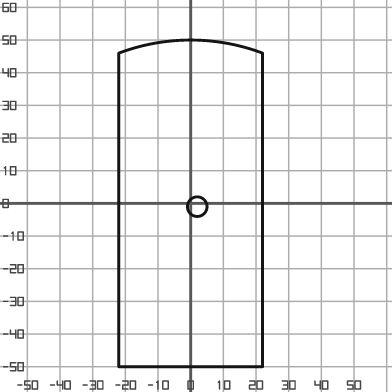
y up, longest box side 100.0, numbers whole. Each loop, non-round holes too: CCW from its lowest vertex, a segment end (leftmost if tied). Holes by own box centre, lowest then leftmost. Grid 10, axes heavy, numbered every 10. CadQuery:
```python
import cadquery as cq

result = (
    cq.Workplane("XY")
    .moveTo(-22.0, -50.0)
    .lineTo(22.0, -50.0)
    .lineTo(22.0, 46.0)
    .threePointArc((0.0, 50.0), (-22.0, 46.0))
    .close()
    .moveTo(2.0, -1.0)
    .circle(3.0)
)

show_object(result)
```